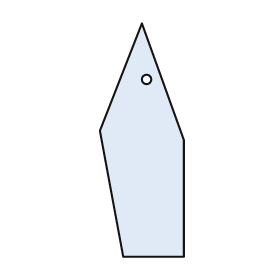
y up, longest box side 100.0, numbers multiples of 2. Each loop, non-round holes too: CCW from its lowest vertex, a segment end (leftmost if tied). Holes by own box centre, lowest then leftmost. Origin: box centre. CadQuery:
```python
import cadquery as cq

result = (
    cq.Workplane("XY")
    .moveTo(-8.0, -50.0)
    .lineTo(18.0, -50.0)
    .lineTo(18.0, 0.0)
    .lineTo(0.0, 50.0)
    .lineTo(-18.0, 4.0)
    .close()
    .moveTo(2.0, 26.0)
    .circle(2.0)
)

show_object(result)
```